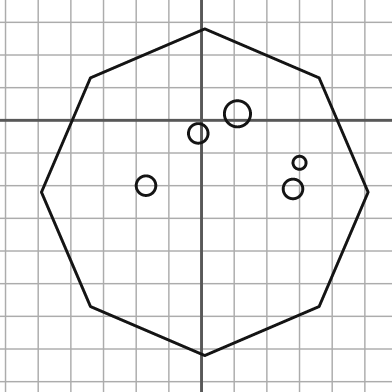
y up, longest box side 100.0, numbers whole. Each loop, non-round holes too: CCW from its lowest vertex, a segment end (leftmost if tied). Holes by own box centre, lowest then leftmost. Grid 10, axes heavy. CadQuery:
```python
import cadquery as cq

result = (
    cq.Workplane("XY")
    .moveTo(1.0, -72.0)
    .lineTo(36.0, -57.0)
    .lineTo(51.0, -22.0)
    .lineTo(36.0, 13.0)
    .lineTo(1.0, 28.0)
    .lineTo(-34.0, 13.0)
    .lineTo(-49.0, -22.0)
    .lineTo(-34.0, -57.0)
    .close()
    .moveTo(28.0, -21.0)
    .circle(3.0)
    .moveTo(-17.0, -20.0)
    .circle(3.0)
    .moveTo(30.0, -13.0)
    .circle(2.0)
    .moveTo(-1.0, -4.0)
    .circle(3.0)
    .moveTo(11.0, 2.0)
    .circle(4.0)
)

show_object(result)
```